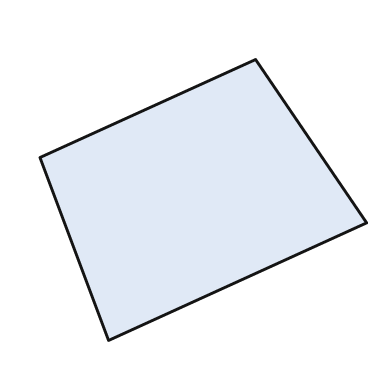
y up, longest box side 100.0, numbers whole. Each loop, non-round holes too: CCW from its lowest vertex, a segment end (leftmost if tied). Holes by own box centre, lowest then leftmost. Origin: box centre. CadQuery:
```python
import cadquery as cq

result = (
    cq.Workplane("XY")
    .moveTo(-29.0, -43.0)
    .lineTo(50.0, -7.0)
    .lineTo(16.0, 43.0)
    .lineTo(-50.0, 13.0)
    .close()
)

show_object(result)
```